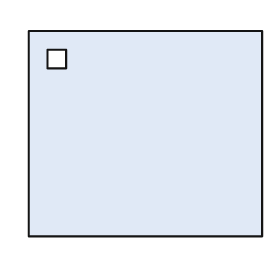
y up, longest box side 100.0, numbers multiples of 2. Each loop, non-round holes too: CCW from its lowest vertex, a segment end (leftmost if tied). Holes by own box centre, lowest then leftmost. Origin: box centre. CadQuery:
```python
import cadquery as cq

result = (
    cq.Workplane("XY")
    .moveTo(-50.0, -44.0)
    .lineTo(50.0, -44.0)
    .lineTo(50.0, 44.0)
    .lineTo(-50.0, 44.0)
    .close()
    .moveTo(-42.0, 28.0)
    .lineTo(-34.0, 28.0)
    .lineTo(-34.0, 36.0)
    .lineTo(-42.0, 36.0)
    .close()
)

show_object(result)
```